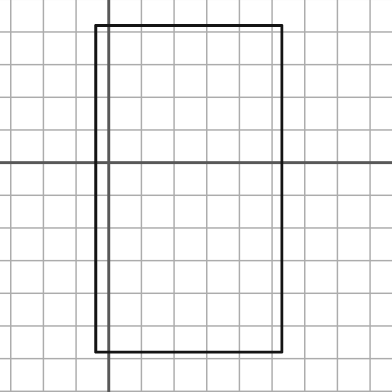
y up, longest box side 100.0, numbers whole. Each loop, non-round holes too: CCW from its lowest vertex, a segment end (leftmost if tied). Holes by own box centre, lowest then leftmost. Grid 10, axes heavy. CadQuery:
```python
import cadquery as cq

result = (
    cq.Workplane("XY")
    .moveTo(-4.0, -58.0)
    .lineTo(53.0, -58.0)
    .lineTo(53.0, 42.0)
    .lineTo(-4.0, 42.0)
    .close()
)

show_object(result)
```